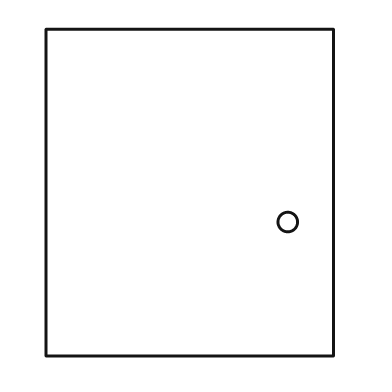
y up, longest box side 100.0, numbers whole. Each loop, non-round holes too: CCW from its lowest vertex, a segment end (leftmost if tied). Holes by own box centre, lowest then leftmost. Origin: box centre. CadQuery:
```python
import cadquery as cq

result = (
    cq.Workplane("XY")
    .moveTo(-44.0, -50.0)
    .lineTo(44.0, -50.0)
    .lineTo(44.0, 50.0)
    .lineTo(-44.0, 50.0)
    .close()
    .moveTo(30.0, -9.0)
    .circle(3.0)
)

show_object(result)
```